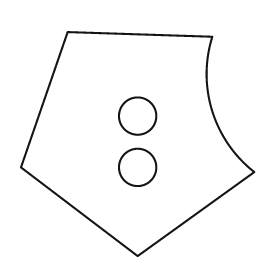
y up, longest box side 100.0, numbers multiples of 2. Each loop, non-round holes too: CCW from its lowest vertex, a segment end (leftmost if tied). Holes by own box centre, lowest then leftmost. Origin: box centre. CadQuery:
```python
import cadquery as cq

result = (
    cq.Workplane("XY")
    .moveTo(0.0, -48.0)
    .lineTo(50.0, -12.0)
    .threePointArc((32.0, 14.0), (32.0, 46.0))
    .lineTo(-30.0, 48.0)
    .lineTo(-50.0, -10.0)
    .close()
    .moveTo(0.0, -10.0)
    .circle(8.0)
    .moveTo(0.0, 12.0)
    .circle(8.0)
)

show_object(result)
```